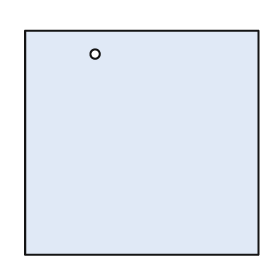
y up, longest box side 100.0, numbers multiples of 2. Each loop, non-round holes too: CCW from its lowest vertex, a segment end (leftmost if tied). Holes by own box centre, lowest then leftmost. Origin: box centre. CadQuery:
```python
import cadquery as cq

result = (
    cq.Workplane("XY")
    .moveTo(-50.0, -48.0)
    .lineTo(50.0, -48.0)
    .lineTo(50.0, 48.0)
    .lineTo(-50.0, 48.0)
    .close()
    .moveTo(-20.0, 38.0)
    .circle(2.0)
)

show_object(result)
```